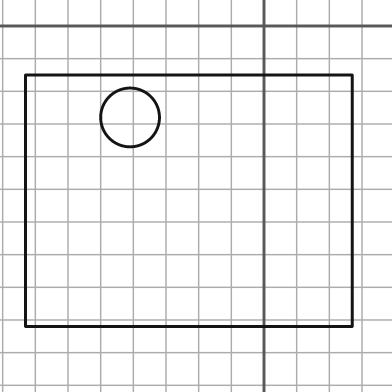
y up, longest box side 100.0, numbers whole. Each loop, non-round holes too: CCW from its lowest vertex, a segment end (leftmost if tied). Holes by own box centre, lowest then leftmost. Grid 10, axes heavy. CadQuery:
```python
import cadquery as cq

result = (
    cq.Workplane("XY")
    .moveTo(-73.0, -92.0)
    .lineTo(27.0, -92.0)
    .lineTo(27.0, -15.0)
    .lineTo(-73.0, -15.0)
    .close()
    .moveTo(-41.0, -28.0)
    .circle(9.0)
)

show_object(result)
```